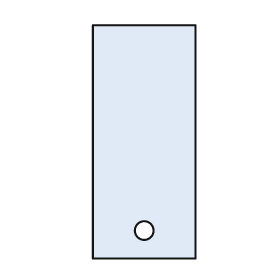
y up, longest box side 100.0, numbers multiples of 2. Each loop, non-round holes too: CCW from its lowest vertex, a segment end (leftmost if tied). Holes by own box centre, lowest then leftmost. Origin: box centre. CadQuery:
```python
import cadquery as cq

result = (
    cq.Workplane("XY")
    .moveTo(-22.0, -50.0)
    .lineTo(22.0, -50.0)
    .lineTo(22.0, 50.0)
    .lineTo(-22.0, 50.0)
    .close()
    .moveTo(0.0, -38.0)
    .circle(4.0)
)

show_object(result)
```